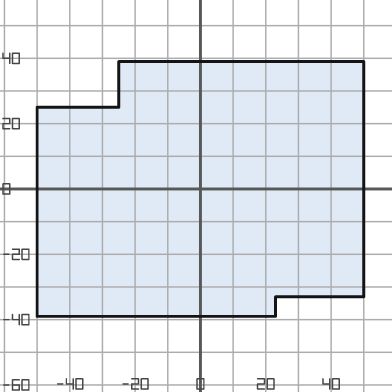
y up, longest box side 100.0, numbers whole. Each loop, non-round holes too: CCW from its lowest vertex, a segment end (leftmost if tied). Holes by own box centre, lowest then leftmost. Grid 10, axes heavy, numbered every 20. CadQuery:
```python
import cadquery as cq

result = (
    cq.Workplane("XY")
    .moveTo(-50.0, -39.0)
    .lineTo(23.0, -39.0)
    .lineTo(23.0, -33.0)
    .lineTo(50.0, -33.0)
    .lineTo(50.0, 39.0)
    .lineTo(-25.0, 39.0)
    .lineTo(-25.0, 25.0)
    .lineTo(-50.0, 25.0)
    .close()
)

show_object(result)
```